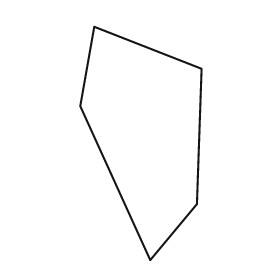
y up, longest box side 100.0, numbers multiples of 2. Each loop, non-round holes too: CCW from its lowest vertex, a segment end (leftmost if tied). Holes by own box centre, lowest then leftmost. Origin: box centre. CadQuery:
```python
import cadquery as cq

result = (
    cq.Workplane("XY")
    .moveTo(4.0, -50.0)
    .lineTo(24.0, -26.0)
    .lineTo(26.0, 32.0)
    .lineTo(-20.0, 50.0)
    .lineTo(-26.0, 16.0)
    .close()
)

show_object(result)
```